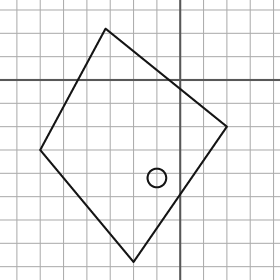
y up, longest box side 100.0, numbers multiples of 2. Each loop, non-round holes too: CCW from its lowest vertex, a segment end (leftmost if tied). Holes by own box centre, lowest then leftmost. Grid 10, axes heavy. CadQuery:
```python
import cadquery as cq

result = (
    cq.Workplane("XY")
    .moveTo(-20.0, -78.0)
    .lineTo(20.0, -20.0)
    .lineTo(-32.0, 22.0)
    .lineTo(-60.0, -30.0)
    .close()
    .moveTo(-10.0, -42.0)
    .circle(4.0)
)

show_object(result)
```